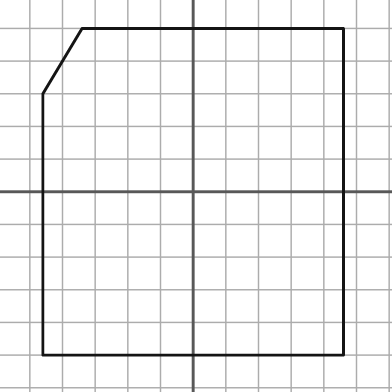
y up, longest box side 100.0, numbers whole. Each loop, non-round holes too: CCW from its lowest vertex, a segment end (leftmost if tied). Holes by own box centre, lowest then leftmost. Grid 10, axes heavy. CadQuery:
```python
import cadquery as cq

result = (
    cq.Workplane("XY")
    .moveTo(-46.0, -50.0)
    .lineTo(46.0, -50.0)
    .lineTo(46.0, 50.0)
    .lineTo(-34.0, 50.0)
    .lineTo(-46.0, 30.0)
    .close()
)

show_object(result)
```